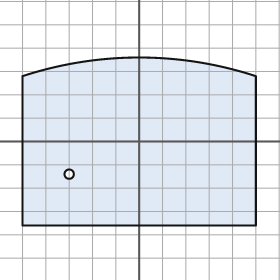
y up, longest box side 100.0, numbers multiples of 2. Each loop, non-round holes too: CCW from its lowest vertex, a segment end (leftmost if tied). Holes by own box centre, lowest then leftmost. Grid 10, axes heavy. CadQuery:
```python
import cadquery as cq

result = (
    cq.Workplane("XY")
    .moveTo(-50.0, -36.0)
    .lineTo(50.0, -36.0)
    .lineTo(50.0, 28.0)
    .threePointArc((0.0, 36.0), (-50.0, 28.0))
    .close()
    .moveTo(-30.0, -14.0)
    .circle(2.0)
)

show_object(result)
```